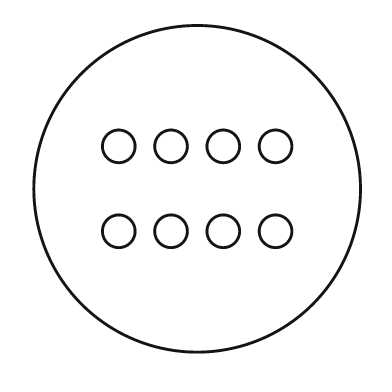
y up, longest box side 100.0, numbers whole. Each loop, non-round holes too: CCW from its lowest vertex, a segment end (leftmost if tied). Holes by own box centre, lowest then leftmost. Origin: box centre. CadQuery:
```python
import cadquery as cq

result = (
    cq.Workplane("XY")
    .moveTo(0.0, 0.0)
    .circle(50.0)
    .moveTo(-24.0, -13.0)
    .circle(5.0)
    .moveTo(-8.0, -13.0)
    .circle(5.0)
    .moveTo(8.0, -13.0)
    .circle(5.0)
    .moveTo(24.0, -13.0)
    .circle(5.0)
    .moveTo(-24.0, 13.0)
    .circle(5.0)
    .moveTo(-8.0, 13.0)
    .circle(5.0)
    .moveTo(8.0, 13.0)
    .circle(5.0)
    .moveTo(24.0, 13.0)
    .circle(5.0)
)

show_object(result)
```